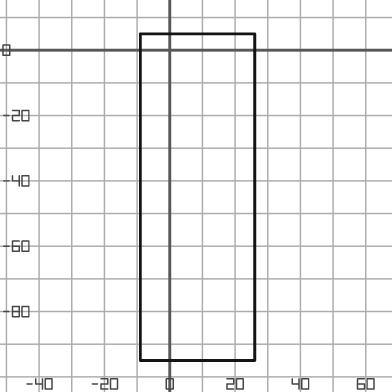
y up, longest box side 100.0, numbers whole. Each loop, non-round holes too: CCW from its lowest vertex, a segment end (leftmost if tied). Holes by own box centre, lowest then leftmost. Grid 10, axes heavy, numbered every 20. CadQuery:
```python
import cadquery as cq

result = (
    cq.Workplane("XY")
    .moveTo(-9.0, -95.0)
    .lineTo(26.0, -95.0)
    .lineTo(26.0, 5.0)
    .lineTo(-9.0, 5.0)
    .close()
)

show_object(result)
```